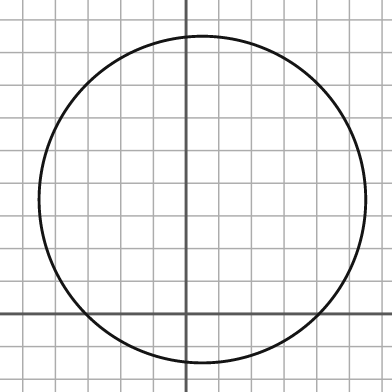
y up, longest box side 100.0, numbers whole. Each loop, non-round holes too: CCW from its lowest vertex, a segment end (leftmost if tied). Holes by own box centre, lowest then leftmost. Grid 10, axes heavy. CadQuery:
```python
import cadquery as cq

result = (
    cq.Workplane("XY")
    .moveTo(5.0, 35.0)
    .circle(50.0)
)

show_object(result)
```